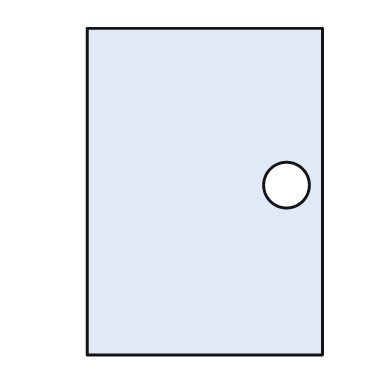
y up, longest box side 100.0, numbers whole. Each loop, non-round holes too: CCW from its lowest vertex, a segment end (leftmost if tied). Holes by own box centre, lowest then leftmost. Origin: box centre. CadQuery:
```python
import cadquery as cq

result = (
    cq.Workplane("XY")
    .moveTo(-36.0, -50.0)
    .lineTo(36.0, -50.0)
    .lineTo(36.0, 50.0)
    .lineTo(-36.0, 50.0)
    .close()
    .moveTo(25.0, 2.0)
    .circle(7.0)
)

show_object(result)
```